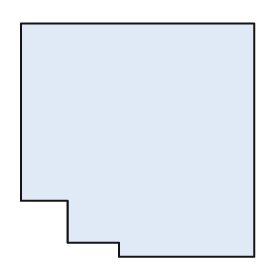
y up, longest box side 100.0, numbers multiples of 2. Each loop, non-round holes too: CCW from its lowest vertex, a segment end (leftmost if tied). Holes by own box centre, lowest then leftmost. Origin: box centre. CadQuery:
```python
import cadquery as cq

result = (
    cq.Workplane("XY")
    .moveTo(-8.0, -50.0)
    .lineTo(50.0, -50.0)
    .lineTo(50.0, 50.0)
    .lineTo(-50.0, 50.0)
    .lineTo(-50.0, -26.0)
    .lineTo(-30.0, -26.0)
    .lineTo(-30.0, -44.0)
    .lineTo(-8.0, -44.0)
    .close()
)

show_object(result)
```